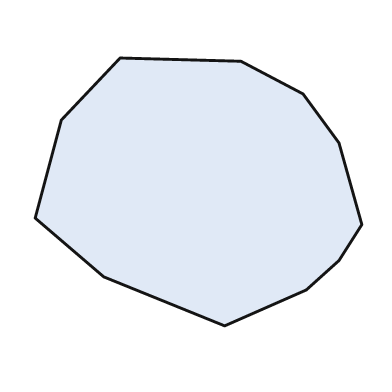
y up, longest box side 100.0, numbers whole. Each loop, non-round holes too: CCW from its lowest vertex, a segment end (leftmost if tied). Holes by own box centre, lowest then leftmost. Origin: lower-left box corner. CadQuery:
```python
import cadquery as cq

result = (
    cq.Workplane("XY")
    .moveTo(58.0, 0.0)
    .lineTo(83.0, 11.0)
    .lineTo(93.0, 20.0)
    .lineTo(100.0, 31.0)
    .lineTo(93.0, 56.0)
    .lineTo(82.0, 71.0)
    .lineTo(63.0, 81.0)
    .lineTo(26.0, 82.0)
    .lineTo(8.0, 63.0)
    .lineTo(0.0, 33.0)
    .lineTo(21.0, 15.0)
    .close()
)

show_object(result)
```